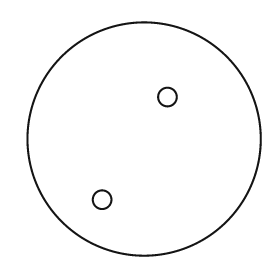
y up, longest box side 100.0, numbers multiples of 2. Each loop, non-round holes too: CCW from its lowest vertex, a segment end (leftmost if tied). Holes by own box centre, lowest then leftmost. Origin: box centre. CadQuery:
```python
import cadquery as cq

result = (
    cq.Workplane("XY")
    .moveTo(0.0, 0.0)
    .circle(50.0)
    .moveTo(-18.0, -26.0)
    .circle(4.0)
    .moveTo(10.0, 18.0)
    .circle(4.0)
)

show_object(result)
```